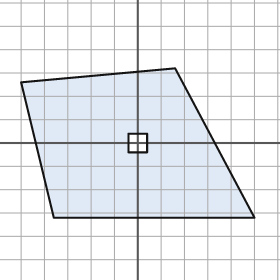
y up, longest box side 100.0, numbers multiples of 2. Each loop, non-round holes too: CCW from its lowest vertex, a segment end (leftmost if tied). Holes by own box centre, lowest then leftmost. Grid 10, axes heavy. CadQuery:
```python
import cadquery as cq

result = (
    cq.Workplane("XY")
    .moveTo(-36.0, -32.0)
    .lineTo(50.0, -32.0)
    .lineTo(16.0, 32.0)
    .lineTo(-50.0, 26.0)
    .close()
    .moveTo(-4.0, -4.0)
    .lineTo(4.0, -4.0)
    .lineTo(4.0, 4.0)
    .lineTo(-4.0, 4.0)
    .close()
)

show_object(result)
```